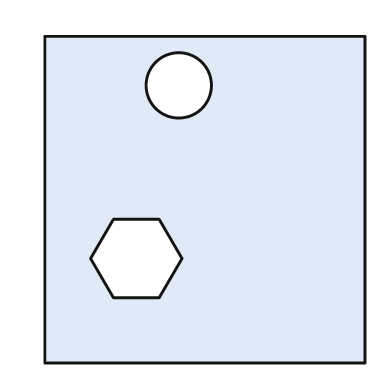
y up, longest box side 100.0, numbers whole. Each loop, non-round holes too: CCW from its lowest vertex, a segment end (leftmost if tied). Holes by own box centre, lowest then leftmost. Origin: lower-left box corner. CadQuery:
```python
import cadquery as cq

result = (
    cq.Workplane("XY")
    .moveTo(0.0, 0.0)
    .lineTo(98.0, 0.0)
    .lineTo(98.0, 100.0)
    .lineTo(0.0, 100.0)
    .close()
    .moveTo(21.0, 20.0)
    .lineTo(35.0, 20.0)
    .lineTo(42.0, 32.0)
    .lineTo(35.0, 44.0)
    .lineTo(21.0, 44.0)
    .lineTo(14.0, 32.0)
    .close()
    .moveTo(41.0, 85.0)
    .circle(10.0)
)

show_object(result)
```